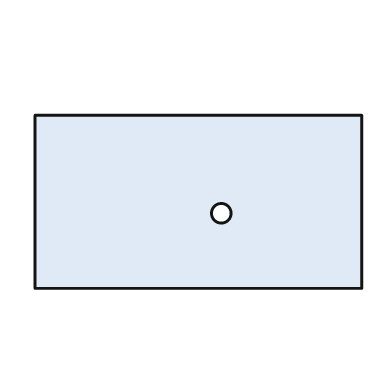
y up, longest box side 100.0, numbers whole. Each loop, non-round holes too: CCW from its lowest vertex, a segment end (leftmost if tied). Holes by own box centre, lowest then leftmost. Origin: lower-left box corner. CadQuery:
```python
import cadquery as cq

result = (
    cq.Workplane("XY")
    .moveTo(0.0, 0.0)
    .lineTo(100.0, 0.0)
    .lineTo(100.0, 53.0)
    .lineTo(0.0, 53.0)
    .close()
    .moveTo(57.0, 23.0)
    .circle(3.0)
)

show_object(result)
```